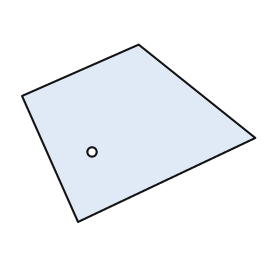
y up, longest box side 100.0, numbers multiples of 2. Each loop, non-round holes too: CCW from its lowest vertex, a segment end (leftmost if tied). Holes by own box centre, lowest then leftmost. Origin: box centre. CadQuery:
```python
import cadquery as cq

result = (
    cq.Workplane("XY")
    .moveTo(-26.0, -38.0)
    .lineTo(50.0, -2.0)
    .lineTo(0.0, 38.0)
    .lineTo(-50.0, 16.0)
    .close()
    .moveTo(-20.0, -8.0)
    .circle(2.0)
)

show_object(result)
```